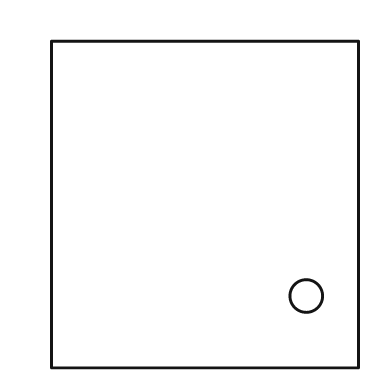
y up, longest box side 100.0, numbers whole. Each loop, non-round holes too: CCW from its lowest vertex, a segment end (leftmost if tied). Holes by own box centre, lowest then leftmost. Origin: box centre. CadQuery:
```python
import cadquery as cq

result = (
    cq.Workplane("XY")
    .moveTo(-47.0, -50.0)
    .lineTo(47.0, -50.0)
    .lineTo(47.0, 50.0)
    .lineTo(-47.0, 50.0)
    .close()
    .moveTo(31.0, -28.0)
    .circle(5.0)
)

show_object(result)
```